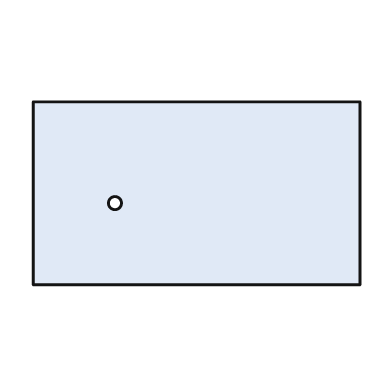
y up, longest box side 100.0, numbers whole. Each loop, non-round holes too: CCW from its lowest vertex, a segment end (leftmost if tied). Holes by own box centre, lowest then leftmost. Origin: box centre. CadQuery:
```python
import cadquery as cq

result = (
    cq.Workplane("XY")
    .moveTo(-50.0, -28.0)
    .lineTo(50.0, -28.0)
    .lineTo(50.0, 28.0)
    .lineTo(-50.0, 28.0)
    .close()
    .moveTo(-25.0, -3.0)
    .circle(2.0)
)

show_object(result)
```